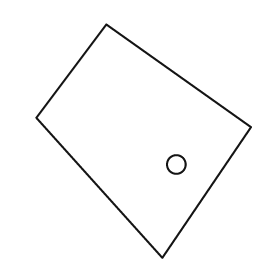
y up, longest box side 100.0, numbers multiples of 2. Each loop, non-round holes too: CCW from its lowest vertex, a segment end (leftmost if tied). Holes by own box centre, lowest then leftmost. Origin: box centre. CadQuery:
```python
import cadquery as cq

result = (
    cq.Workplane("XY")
    .moveTo(8.0, -50.0)
    .lineTo(46.0, 6.0)
    .lineTo(-16.0, 50.0)
    .lineTo(-46.0, 10.0)
    .close()
    .moveTo(14.0, -10.0)
    .circle(4.0)
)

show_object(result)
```